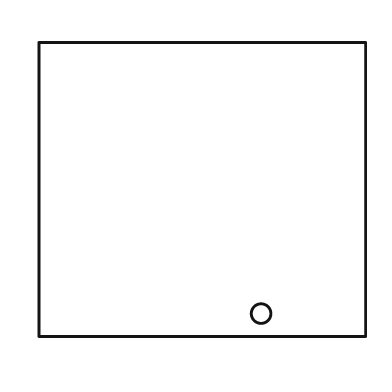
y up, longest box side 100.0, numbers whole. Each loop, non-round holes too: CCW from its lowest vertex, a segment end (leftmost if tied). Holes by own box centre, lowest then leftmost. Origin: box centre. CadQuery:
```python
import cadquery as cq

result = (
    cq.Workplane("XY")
    .moveTo(-50.0, -45.0)
    .lineTo(50.0, -45.0)
    .lineTo(50.0, 45.0)
    .lineTo(-50.0, 45.0)
    .close()
    .moveTo(18.0, -38.0)
    .circle(3.0)
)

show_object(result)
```